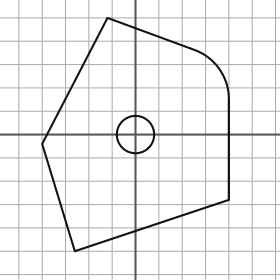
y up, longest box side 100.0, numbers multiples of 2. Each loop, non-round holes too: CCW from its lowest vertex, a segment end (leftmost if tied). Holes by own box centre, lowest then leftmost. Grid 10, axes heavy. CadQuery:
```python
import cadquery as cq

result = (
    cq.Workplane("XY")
    .moveTo(-26.0, -50.0)
    .lineTo(40.0, -28.0)
    .lineTo(40.0, 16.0)
    .threePointArc((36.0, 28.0), (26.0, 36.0))
    .lineTo(-12.0, 50.0)
    .lineTo(-40.0, -4.0)
    .close()
    .moveTo(0.0, 0.0)
    .circle(8.0)
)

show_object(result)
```